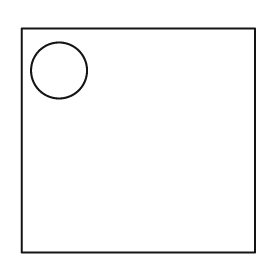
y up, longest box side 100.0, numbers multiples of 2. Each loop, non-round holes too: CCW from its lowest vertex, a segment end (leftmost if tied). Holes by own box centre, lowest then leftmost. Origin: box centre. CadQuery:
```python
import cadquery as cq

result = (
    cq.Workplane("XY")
    .moveTo(-50.0, -48.0)
    .lineTo(50.0, -48.0)
    .lineTo(50.0, 48.0)
    .lineTo(-50.0, 48.0)
    .close()
    .moveTo(-34.0, 30.0)
    .circle(12.0)
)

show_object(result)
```